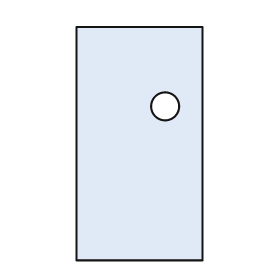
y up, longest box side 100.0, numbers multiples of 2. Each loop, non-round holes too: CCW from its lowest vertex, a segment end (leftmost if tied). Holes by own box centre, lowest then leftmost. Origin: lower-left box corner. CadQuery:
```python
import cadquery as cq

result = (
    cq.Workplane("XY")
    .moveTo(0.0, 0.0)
    .lineTo(54.0, 0.0)
    .lineTo(54.0, 100.0)
    .lineTo(0.0, 100.0)
    .close()
    .moveTo(38.0, 66.0)
    .circle(6.0)
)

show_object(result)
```